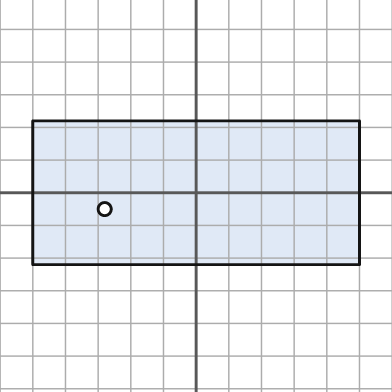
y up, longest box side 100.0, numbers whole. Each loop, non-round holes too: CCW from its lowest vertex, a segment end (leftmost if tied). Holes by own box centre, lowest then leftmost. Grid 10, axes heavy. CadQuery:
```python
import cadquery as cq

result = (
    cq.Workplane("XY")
    .moveTo(-50.0, -22.0)
    .lineTo(50.0, -22.0)
    .lineTo(50.0, 22.0)
    .lineTo(-50.0, 22.0)
    .close()
    .moveTo(-28.0, -5.0)
    .circle(2.0)
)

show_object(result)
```